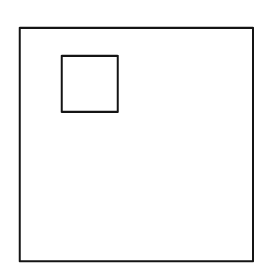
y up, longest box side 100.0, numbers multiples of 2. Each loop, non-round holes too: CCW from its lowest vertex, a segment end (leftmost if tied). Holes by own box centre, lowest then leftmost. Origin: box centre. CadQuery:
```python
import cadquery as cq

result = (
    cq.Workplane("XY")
    .moveTo(-50.0, -50.0)
    .lineTo(50.0, -50.0)
    .lineTo(50.0, 50.0)
    .lineTo(-50.0, 50.0)
    .close()
    .moveTo(-32.0, 14.0)
    .lineTo(-8.0, 14.0)
    .lineTo(-8.0, 38.0)
    .lineTo(-32.0, 38.0)
    .close()
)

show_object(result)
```